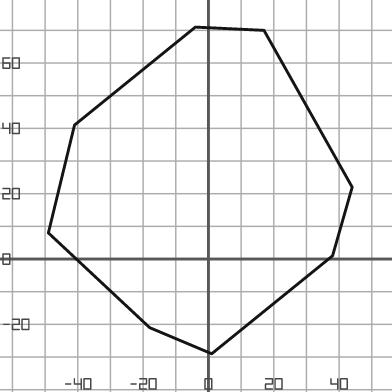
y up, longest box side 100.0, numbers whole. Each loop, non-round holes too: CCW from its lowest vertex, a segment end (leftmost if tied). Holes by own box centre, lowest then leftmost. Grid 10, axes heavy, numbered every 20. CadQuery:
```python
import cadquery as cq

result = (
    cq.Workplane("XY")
    .moveTo(1.0, -29.0)
    .lineTo(38.0, 1.0)
    .lineTo(44.0, 22.0)
    .lineTo(17.0, 70.0)
    .lineTo(-4.0, 71.0)
    .lineTo(-41.0, 41.0)
    .lineTo(-49.0, 8.0)
    .lineTo(-18.0, -21.0)
    .close()
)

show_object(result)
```